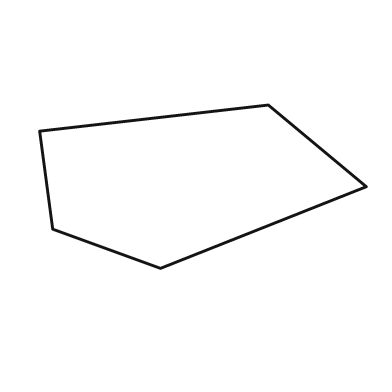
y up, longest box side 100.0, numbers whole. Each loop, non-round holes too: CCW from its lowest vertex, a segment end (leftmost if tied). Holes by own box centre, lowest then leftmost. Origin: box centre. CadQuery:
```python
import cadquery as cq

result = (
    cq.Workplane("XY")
    .moveTo(-13.0, -25.0)
    .lineTo(50.0, 0.0)
    .lineTo(20.0, 25.0)
    .lineTo(-50.0, 17.0)
    .lineTo(-46.0, -13.0)
    .close()
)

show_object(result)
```